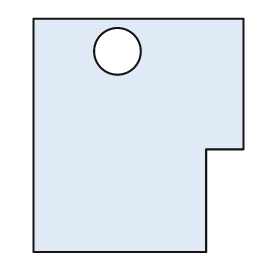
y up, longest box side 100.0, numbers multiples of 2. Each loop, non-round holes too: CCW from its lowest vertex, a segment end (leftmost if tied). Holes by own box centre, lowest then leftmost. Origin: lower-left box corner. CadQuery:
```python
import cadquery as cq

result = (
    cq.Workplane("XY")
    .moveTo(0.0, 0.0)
    .lineTo(74.0, 0.0)
    .lineTo(74.0, 44.0)
    .lineTo(90.0, 44.0)
    .lineTo(90.0, 100.0)
    .lineTo(0.0, 100.0)
    .close()
    .moveTo(36.0, 86.0)
    .circle(10.0)
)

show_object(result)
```